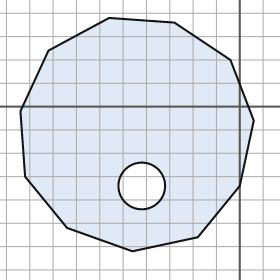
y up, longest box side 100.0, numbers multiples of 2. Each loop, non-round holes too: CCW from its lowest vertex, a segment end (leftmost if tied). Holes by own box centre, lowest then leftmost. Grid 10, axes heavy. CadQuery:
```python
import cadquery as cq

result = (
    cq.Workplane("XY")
    .moveTo(-46.0, -62.0)
    .lineTo(-18.0, -56.0)
    .lineTo(0.0, -34.0)
    .lineTo(6.0, -6.0)
    .lineTo(-4.0, 20.0)
    .lineTo(-28.0, 36.0)
    .lineTo(-56.0, 38.0)
    .lineTo(-82.0, 24.0)
    .lineTo(-94.0, -2.0)
    .lineTo(-92.0, -30.0)
    .lineTo(-74.0, -52.0)
    .close()
    .moveTo(-42.0, -34.0)
    .circle(10.0)
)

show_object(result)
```